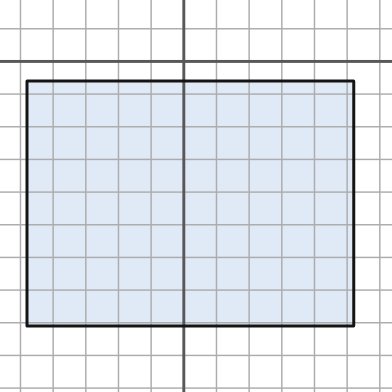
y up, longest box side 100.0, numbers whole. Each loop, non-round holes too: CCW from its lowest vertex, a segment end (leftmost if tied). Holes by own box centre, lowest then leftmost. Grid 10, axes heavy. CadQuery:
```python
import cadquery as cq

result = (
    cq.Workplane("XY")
    .moveTo(-48.0, -81.0)
    .lineTo(52.0, -81.0)
    .lineTo(52.0, -6.0)
    .lineTo(-48.0, -6.0)
    .close()
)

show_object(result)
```